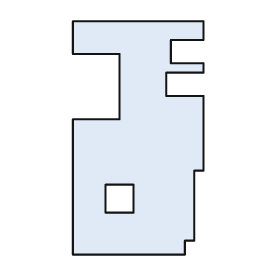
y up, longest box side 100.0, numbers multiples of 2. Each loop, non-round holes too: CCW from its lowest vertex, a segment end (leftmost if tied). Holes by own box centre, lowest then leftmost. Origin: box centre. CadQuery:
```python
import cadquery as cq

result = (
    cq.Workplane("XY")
    .moveTo(-28.0, -50.0)
    .lineTo(20.0, -50.0)
    .lineTo(20.0, -44.0)
    .lineTo(24.0, -44.0)
    .lineTo(24.0, -14.0)
    .lineTo(28.0, -14.0)
    .lineTo(28.0, 18.0)
    .lineTo(12.0, 18.0)
    .lineTo(12.0, 28.0)
    .lineTo(28.0, 28.0)
    .lineTo(28.0, 32.0)
    .lineTo(14.0, 32.0)
    .lineTo(14.0, 42.0)
    .lineTo(28.0, 42.0)
    .lineTo(28.0, 50.0)
    .lineTo(-28.0, 50.0)
    .lineTo(-28.0, 36.0)
    .lineTo(-8.0, 36.0)
    .lineTo(-8.0, 8.0)
    .lineTo(-28.0, 8.0)
    .close()
    .moveTo(-14.0, -32.0)
    .lineTo(-2.0, -32.0)
    .lineTo(-2.0, -20.0)
    .lineTo(-14.0, -20.0)
    .close()
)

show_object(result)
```